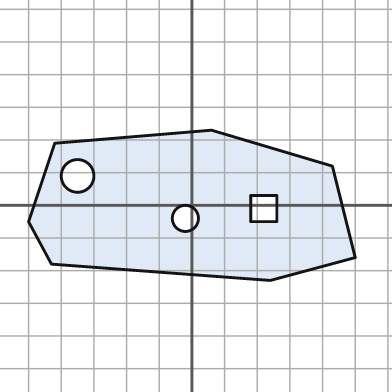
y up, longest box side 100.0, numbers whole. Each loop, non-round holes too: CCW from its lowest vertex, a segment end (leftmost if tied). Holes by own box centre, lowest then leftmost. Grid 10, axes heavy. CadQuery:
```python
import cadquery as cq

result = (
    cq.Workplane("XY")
    .moveTo(24.0, -23.0)
    .lineTo(50.0, -16.0)
    .lineTo(43.0, 12.0)
    .lineTo(6.0, 23.0)
    .lineTo(-42.0, 19.0)
    .lineTo(-50.0, -5.0)
    .lineTo(-43.0, -18.0)
    .close()
    .moveTo(-2.0, -4.0)
    .circle(4.0)
    .moveTo(18.0, -5.0)
    .lineTo(26.0, -5.0)
    .lineTo(26.0, 3.0)
    .lineTo(18.0, 3.0)
    .close()
    .moveTo(-35.0, 9.0)
    .circle(5.0)
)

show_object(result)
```